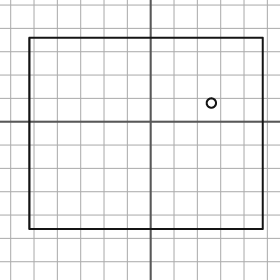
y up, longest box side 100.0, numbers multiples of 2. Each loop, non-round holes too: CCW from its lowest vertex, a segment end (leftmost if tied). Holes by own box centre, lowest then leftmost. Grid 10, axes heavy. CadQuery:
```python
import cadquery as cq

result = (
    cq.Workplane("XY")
    .moveTo(-52.0, -46.0)
    .lineTo(48.0, -46.0)
    .lineTo(48.0, 36.0)
    .lineTo(-52.0, 36.0)
    .close()
    .moveTo(26.0, 8.0)
    .circle(2.0)
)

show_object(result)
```